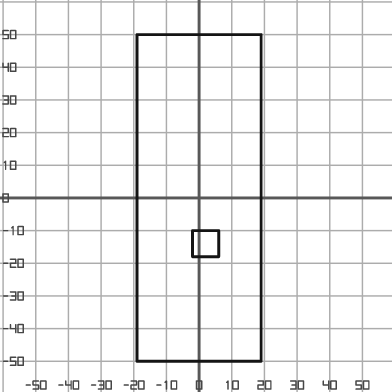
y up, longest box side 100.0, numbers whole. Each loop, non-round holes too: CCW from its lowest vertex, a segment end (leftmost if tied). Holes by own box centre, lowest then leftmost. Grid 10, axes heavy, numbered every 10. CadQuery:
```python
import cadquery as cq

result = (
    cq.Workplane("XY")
    .moveTo(-19.0, -50.0)
    .lineTo(19.0, -50.0)
    .lineTo(19.0, 50.0)
    .lineTo(-19.0, 50.0)
    .close()
    .moveTo(-2.0, -18.0)
    .lineTo(6.0, -18.0)
    .lineTo(6.0, -10.0)
    .lineTo(-2.0, -10.0)
    .close()
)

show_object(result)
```